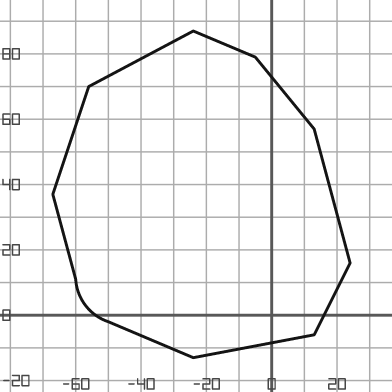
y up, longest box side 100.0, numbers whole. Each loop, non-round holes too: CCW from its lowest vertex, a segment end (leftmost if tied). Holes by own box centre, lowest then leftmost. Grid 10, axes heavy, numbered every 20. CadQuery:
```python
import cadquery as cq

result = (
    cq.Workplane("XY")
    .moveTo(-24.0, -13.0)
    .lineTo(13.0, -6.0)
    .lineTo(24.0, 16.0)
    .lineTo(13.0, 57.0)
    .lineTo(-5.0, 79.0)
    .lineTo(-24.0, 87.0)
    .lineTo(-56.0, 70.0)
    .lineTo(-67.0, 37.0)
    .lineTo(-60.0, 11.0)
    .threePointArc((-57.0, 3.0), (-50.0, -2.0))
    .close()
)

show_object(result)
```